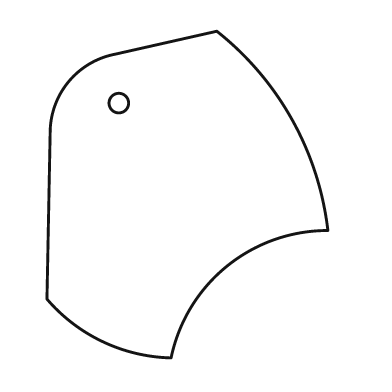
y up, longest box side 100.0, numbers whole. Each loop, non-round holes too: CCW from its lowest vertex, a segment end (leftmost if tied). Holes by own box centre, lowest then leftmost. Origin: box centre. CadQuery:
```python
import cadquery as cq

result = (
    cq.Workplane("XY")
    .moveTo(-5.0, -50.0)
    .threePointArc((12.0, -22.0), (43.0, -11.0))
    .threePointArc((32.0, 23.0), (9.0, 50.0))
    .lineTo(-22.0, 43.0)
    .threePointArc((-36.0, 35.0), (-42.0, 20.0))
    .lineTo(-43.0, -32.0)
    .threePointArc((-26.0, -45.0), (-5.0, -50.0))
    .close()
    .moveTo(-21.0, 28.0)
    .circle(3.0)
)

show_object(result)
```